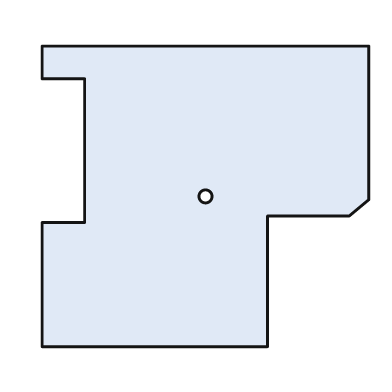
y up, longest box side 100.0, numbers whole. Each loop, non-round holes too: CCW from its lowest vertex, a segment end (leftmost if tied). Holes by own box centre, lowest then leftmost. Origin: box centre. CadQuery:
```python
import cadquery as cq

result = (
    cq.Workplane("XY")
    .moveTo(-50.0, -46.0)
    .lineTo(19.0, -46.0)
    .lineTo(19.0, -6.0)
    .lineTo(44.0, -6.0)
    .lineTo(50.0, -1.0)
    .lineTo(50.0, 46.0)
    .lineTo(-50.0, 46.0)
    .lineTo(-50.0, 36.0)
    .lineTo(-37.0, 36.0)
    .lineTo(-37.0, -8.0)
    .lineTo(-50.0, -8.0)
    .close()
    .moveTo(0.0, 0.0)
    .circle(2.0)
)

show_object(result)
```